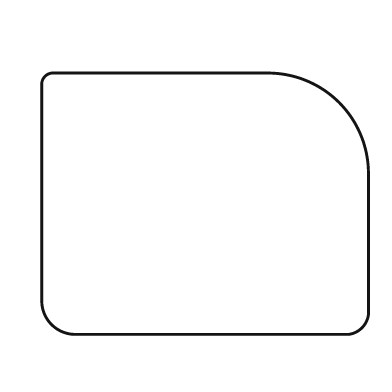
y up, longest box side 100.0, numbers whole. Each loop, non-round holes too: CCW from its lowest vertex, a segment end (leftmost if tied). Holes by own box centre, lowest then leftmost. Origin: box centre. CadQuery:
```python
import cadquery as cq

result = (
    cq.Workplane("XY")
    .moveTo(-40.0, -40.0)
    .lineTo(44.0, -40.0)
    .threePointArc((48.0, -38.0), (50.0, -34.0))
    .lineTo(50.0, 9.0)
    .threePointArc((41.0, 31.0), (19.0, 40.0))
    .lineTo(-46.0, 40.0)
    .threePointArc((-49.0, 39.0), (-50.0, 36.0))
    .lineTo(-50.0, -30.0)
    .threePointArc((-47.0, -37.0), (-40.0, -40.0))
    .close()
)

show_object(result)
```